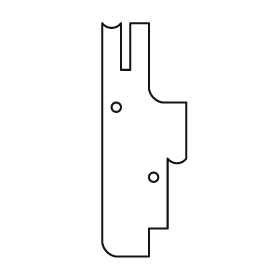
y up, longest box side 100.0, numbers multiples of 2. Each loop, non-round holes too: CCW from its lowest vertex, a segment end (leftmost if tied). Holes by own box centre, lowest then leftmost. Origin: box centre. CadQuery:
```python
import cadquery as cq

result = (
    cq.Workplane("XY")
    .moveTo(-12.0, -50.0)
    .lineTo(2.0, -50.0)
    .lineTo(2.0, -38.0)
    .lineTo(10.0, -38.0)
    .lineTo(10.0, -8.0)
    .threePointArc((14.0, -10.0), (18.0, -8.0))
    .lineTo(18.0, 16.0)
    .lineTo(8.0, 16.0)
    .threePointArc((4.0, 18.0), (2.0, 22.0))
    .lineTo(2.0, 50.0)
    .lineTo(-6.0, 50.0)
    .lineTo(-6.0, 30.0)
    .lineTo(-10.0, 30.0)
    .lineTo(-10.0, 50.0)
    .threePointArc((-14.0, 48.0), (-18.0, 50.0))
    .lineTo(-18.0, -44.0)
    .threePointArc((-16.0, -48.0), (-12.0, -50.0))
    .close()
    .moveTo(4.0, -16.0)
    .circle(2.0)
    .moveTo(-12.0, 14.0)
    .circle(2.0)
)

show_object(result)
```